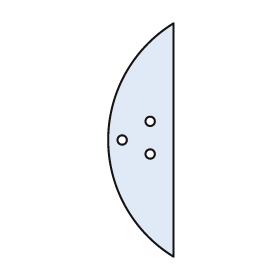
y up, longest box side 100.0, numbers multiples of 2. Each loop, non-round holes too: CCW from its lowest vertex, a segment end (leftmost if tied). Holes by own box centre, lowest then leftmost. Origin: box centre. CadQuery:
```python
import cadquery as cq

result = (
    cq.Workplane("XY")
    .moveTo(14.0, -50.0)
    .lineTo(14.0, 50.0)
    .threePointArc((-14.0, 0.0), (14.0, -50.0))
    .close()
    .moveTo(4.0, -6.0)
    .circle(2.0)
    .moveTo(-8.0, 0.0)
    .circle(2.0)
    .moveTo(4.0, 8.0)
    .circle(2.0)
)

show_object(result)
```